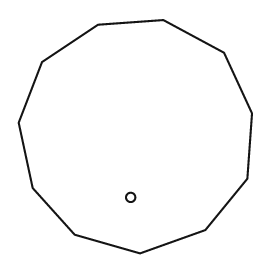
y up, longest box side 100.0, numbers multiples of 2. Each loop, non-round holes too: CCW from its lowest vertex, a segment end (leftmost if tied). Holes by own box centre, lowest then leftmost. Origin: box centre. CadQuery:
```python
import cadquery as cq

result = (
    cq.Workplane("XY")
    .moveTo(2.0, -50.0)
    .lineTo(30.0, -40.0)
    .lineTo(48.0, -18.0)
    .lineTo(50.0, 10.0)
    .lineTo(38.0, 36.0)
    .lineTo(12.0, 50.0)
    .lineTo(-16.0, 48.0)
    .lineTo(-40.0, 32.0)
    .lineTo(-50.0, 6.0)
    .lineTo(-44.0, -22.0)
    .lineTo(-26.0, -42.0)
    .close()
    .moveTo(-2.0, -26.0)
    .circle(2.0)
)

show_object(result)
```